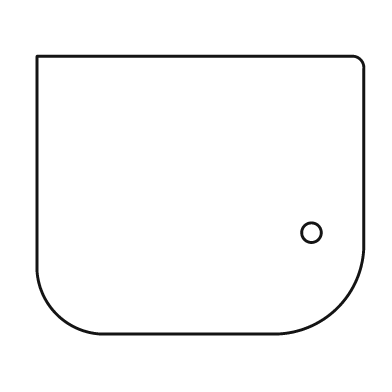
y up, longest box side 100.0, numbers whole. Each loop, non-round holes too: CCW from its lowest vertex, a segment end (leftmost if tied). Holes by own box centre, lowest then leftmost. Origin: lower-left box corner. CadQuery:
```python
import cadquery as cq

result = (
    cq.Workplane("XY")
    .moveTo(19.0, 0.0)
    .lineTo(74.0, 0.0)
    .threePointArc((92.0, 8.0), (100.0, 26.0))
    .lineTo(100.0, 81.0)
    .threePointArc((99.0, 84.0), (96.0, 85.0))
    .lineTo(0.0, 85.0)
    .lineTo(0.0, 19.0)
    .threePointArc((6.0, 6.0), (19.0, 0.0))
    .close()
    .moveTo(84.0, 31.0)
    .circle(3.0)
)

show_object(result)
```